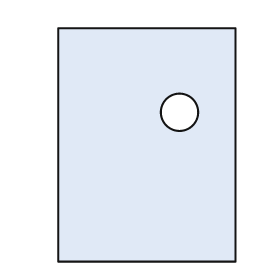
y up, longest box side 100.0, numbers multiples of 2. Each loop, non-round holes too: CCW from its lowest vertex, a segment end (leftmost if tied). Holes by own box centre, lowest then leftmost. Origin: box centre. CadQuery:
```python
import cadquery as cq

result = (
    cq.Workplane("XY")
    .moveTo(-38.0, -50.0)
    .lineTo(38.0, -50.0)
    .lineTo(38.0, 50.0)
    .lineTo(-38.0, 50.0)
    .close()
    .moveTo(14.0, 14.0)
    .circle(8.0)
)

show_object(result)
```